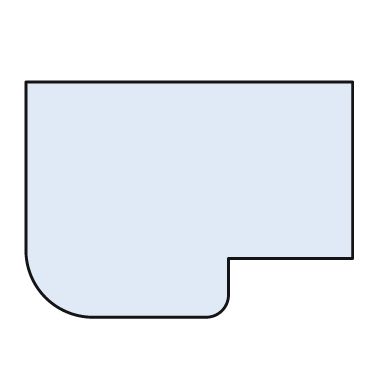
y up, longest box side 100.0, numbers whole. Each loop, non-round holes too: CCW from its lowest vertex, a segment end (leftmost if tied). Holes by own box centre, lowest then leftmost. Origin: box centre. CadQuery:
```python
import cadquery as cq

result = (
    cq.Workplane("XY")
    .moveTo(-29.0, -36.0)
    .lineTo(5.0, -36.0)
    .threePointArc((10.0, -34.0), (12.0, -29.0))
    .lineTo(12.0, -18.0)
    .lineTo(50.0, -18.0)
    .lineTo(50.0, 36.0)
    .lineTo(-50.0, 36.0)
    .lineTo(-50.0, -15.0)
    .threePointArc((-44.0, -30.0), (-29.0, -36.0))
    .close()
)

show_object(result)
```